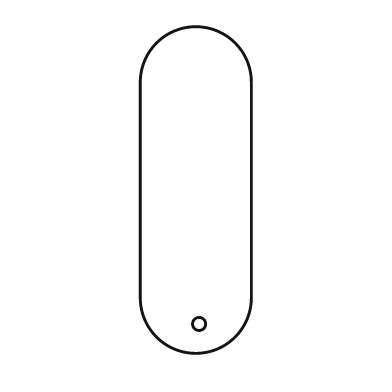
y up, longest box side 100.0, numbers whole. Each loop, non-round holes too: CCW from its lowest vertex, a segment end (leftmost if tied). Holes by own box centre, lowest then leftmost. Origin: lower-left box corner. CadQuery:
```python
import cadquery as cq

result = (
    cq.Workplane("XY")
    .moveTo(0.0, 17.0)
    .threePointArc((17.0, 0.0), (34.0, 17.0))
    .lineTo(34.0, 83.0)
    .threePointArc((17.0, 100.0), (0.0, 83.0))
    .close()
    .moveTo(18.0, 9.0)
    .circle(2.0)
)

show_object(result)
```